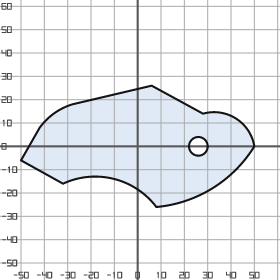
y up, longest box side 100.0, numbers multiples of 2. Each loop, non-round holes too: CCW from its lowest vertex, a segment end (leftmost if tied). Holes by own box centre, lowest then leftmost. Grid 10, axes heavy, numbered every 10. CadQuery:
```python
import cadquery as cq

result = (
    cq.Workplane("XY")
    .moveTo(8.0, -26.0)
    .threePointArc((32.0, -18.0), (50.0, 0.0))
    .threePointArc((42.0, 12.0), (28.0, 14.0))
    .lineTo(6.0, 26.0)
    .lineTo(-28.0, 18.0)
    .threePointArc((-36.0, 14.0), (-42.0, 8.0))
    .lineTo(-50.0, -6.0)
    .lineTo(-32.0, -16.0)
    .threePointArc((-10.0, -14.0), (8.0, -26.0))
    .close()
    .moveTo(26.0, 0.0)
    .circle(4.0)
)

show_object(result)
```